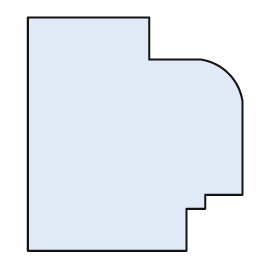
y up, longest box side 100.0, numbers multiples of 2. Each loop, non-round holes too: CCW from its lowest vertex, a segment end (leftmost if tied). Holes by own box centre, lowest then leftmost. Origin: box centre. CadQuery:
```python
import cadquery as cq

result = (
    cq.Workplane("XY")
    .moveTo(-46.0, -50.0)
    .lineTo(22.0, -50.0)
    .lineTo(22.0, -32.0)
    .lineTo(30.0, -32.0)
    .lineTo(30.0, -26.0)
    .lineTo(46.0, -26.0)
    .lineTo(46.0, 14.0)
    .threePointArc((40.0, 26.0), (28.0, 32.0))
    .lineTo(6.0, 32.0)
    .lineTo(6.0, 50.0)
    .lineTo(-46.0, 50.0)
    .close()
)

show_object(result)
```